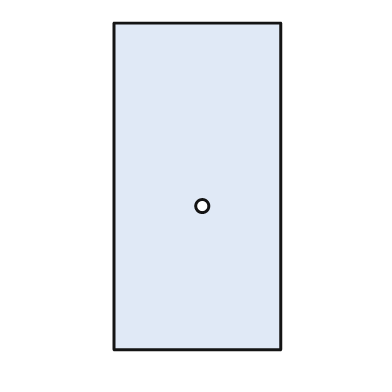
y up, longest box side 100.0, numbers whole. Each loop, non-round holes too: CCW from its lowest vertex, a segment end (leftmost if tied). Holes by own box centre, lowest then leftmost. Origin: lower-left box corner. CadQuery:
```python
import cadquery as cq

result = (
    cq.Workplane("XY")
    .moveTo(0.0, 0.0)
    .lineTo(51.0, 0.0)
    .lineTo(51.0, 100.0)
    .lineTo(0.0, 100.0)
    .close()
    .moveTo(27.0, 44.0)
    .circle(2.0)
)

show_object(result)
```